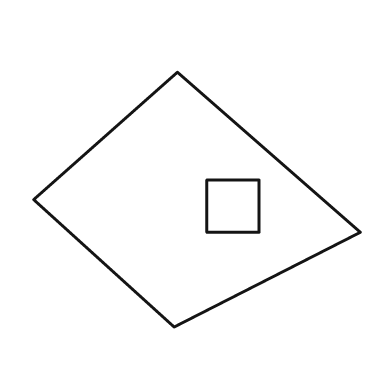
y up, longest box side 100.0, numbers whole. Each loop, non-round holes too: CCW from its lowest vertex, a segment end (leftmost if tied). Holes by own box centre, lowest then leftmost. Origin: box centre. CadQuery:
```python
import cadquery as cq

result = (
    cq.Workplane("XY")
    .moveTo(-7.0, -39.0)
    .lineTo(50.0, -10.0)
    .lineTo(-6.0, 39.0)
    .lineTo(-50.0, 0.0)
    .close()
    .moveTo(3.0, -10.0)
    .lineTo(19.0, -10.0)
    .lineTo(19.0, 6.0)
    .lineTo(3.0, 6.0)
    .close()
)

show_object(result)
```